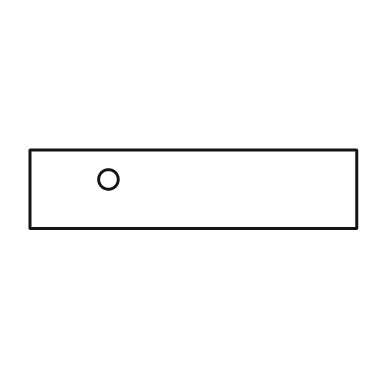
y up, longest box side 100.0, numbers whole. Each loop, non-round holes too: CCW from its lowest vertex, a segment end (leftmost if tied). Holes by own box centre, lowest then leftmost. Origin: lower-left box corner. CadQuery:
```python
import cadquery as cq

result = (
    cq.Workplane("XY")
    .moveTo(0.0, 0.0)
    .lineTo(100.0, 0.0)
    .lineTo(100.0, 24.0)
    .lineTo(0.0, 24.0)
    .close()
    .moveTo(24.0, 15.0)
    .circle(3.0)
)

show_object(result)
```